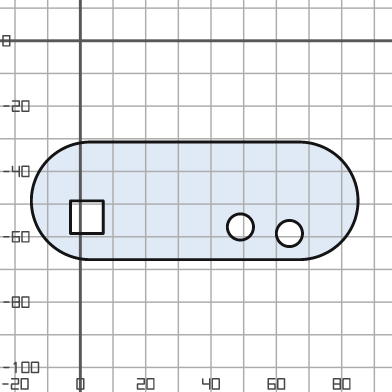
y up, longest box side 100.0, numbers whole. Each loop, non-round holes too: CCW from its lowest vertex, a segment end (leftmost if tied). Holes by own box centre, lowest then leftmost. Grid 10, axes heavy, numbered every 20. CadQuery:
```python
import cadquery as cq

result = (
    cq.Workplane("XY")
    .moveTo(3.0, -67.0)
    .lineTo(67.0, -67.0)
    .threePointArc((85.0, -49.0), (67.0, -31.0))
    .lineTo(3.0, -31.0)
    .threePointArc((-15.0, -49.0), (3.0, -67.0))
    .close()
    .moveTo(64.0, -59.0)
    .circle(4.0)
    .moveTo(49.0, -57.0)
    .circle(4.0)
    .moveTo(-3.0, -59.0)
    .lineTo(7.0, -59.0)
    .lineTo(7.0, -49.0)
    .lineTo(-3.0, -49.0)
    .close()
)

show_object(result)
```